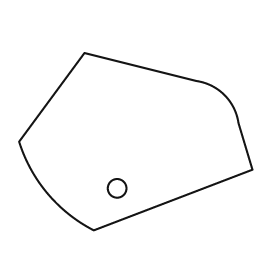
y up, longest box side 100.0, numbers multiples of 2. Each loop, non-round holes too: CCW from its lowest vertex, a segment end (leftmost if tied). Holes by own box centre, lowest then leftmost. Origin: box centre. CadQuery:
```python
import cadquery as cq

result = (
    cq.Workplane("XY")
    .moveTo(-18.0, -38.0)
    .lineTo(50.0, -12.0)
    .lineTo(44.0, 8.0)
    .threePointArc((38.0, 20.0), (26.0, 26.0))
    .lineTo(-22.0, 38.0)
    .lineTo(-50.0, 0.0)
    .threePointArc((-38.0, -22.0), (-18.0, -38.0))
    .close()
    .moveTo(-8.0, -20.0)
    .circle(4.0)
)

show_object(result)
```